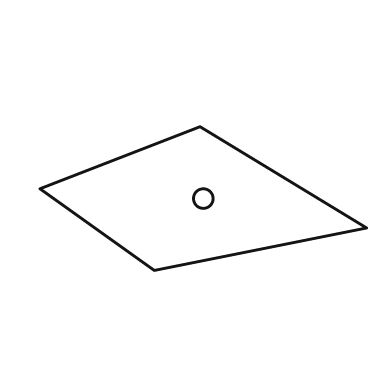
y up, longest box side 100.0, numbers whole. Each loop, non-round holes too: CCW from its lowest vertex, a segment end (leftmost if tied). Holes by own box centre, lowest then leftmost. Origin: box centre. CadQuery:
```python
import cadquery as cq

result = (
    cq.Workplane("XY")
    .moveTo(-15.0, -22.0)
    .lineTo(50.0, -9.0)
    .lineTo(-1.0, 22.0)
    .lineTo(-50.0, 3.0)
    .close()
    .moveTo(0.0, 0.0)
    .circle(3.0)
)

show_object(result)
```